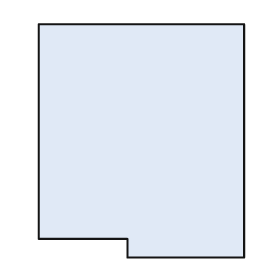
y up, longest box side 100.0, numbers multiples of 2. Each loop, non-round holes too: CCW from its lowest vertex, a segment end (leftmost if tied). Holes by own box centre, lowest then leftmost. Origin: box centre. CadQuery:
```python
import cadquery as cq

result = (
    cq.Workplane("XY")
    .moveTo(-6.0, -50.0)
    .lineTo(44.0, -50.0)
    .lineTo(44.0, 50.0)
    .lineTo(-44.0, 50.0)
    .lineTo(-44.0, -42.0)
    .lineTo(-6.0, -42.0)
    .close()
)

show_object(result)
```